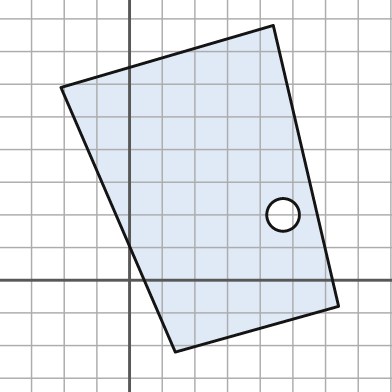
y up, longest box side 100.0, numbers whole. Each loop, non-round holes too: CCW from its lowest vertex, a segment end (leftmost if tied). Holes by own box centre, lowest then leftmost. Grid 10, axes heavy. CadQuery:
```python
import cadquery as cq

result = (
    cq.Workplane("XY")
    .moveTo(14.0, -22.0)
    .lineTo(64.0, -8.0)
    .lineTo(44.0, 78.0)
    .lineTo(-21.0, 59.0)
    .close()
    .moveTo(47.0, 20.0)
    .circle(5.0)
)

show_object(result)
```